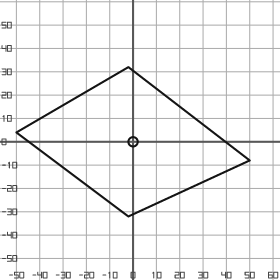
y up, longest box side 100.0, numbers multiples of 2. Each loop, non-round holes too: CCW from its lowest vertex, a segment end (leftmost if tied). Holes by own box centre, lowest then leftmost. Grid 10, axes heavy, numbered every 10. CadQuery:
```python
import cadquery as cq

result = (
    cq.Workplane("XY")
    .moveTo(-2.0, -32.0)
    .lineTo(50.0, -8.0)
    .lineTo(-2.0, 32.0)
    .lineTo(-50.0, 4.0)
    .close()
    .moveTo(0.0, 0.0)
    .circle(2.0)
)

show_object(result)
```